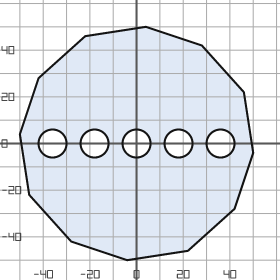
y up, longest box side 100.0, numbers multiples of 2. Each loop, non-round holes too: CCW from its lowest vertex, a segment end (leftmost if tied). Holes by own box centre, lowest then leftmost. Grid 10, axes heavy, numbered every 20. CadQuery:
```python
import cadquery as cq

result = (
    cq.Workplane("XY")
    .moveTo(-4.0, -50.0)
    .lineTo(22.0, -46.0)
    .lineTo(42.0, -28.0)
    .lineTo(50.0, -4.0)
    .lineTo(46.0, 22.0)
    .lineTo(28.0, 42.0)
    .lineTo(4.0, 50.0)
    .lineTo(-22.0, 46.0)
    .lineTo(-42.0, 28.0)
    .lineTo(-50.0, 4.0)
    .lineTo(-46.0, -22.0)
    .lineTo(-28.0, -42.0)
    .close()
    .moveTo(-36.0, 0.0)
    .circle(6.0)
    .moveTo(-18.0, 0.0)
    .circle(6.0)
    .moveTo(0.0, 0.0)
    .circle(6.0)
    .moveTo(18.0, 0.0)
    .circle(6.0)
    .moveTo(36.0, 0.0)
    .circle(6.0)
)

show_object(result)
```